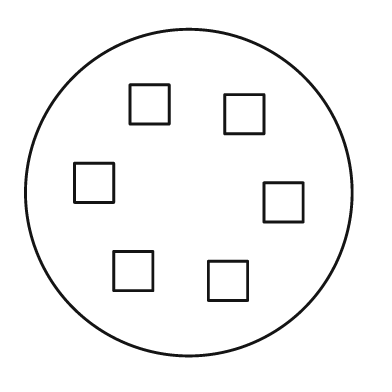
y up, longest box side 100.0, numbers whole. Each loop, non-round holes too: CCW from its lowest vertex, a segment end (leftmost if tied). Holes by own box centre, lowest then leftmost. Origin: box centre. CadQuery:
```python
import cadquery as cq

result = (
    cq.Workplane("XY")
    .moveTo(0.0, 0.0)
    .circle(50.0)
    .moveTo(6.0, -33.0)
    .lineTo(18.0, -33.0)
    .lineTo(18.0, -21.0)
    .lineTo(6.0, -21.0)
    .close()
    .moveTo(-23.0, -30.0)
    .lineTo(-11.0, -30.0)
    .lineTo(-11.0, -18.0)
    .lineTo(-23.0, -18.0)
    .close()
    .moveTo(23.0, -9.0)
    .lineTo(35.0, -9.0)
    .lineTo(35.0, 3.0)
    .lineTo(23.0, 3.0)
    .close()
    .moveTo(-35.0, -3.0)
    .lineTo(-23.0, -3.0)
    .lineTo(-23.0, 9.0)
    .lineTo(-35.0, 9.0)
    .close()
    .moveTo(11.0, 18.0)
    .lineTo(23.0, 18.0)
    .lineTo(23.0, 30.0)
    .lineTo(11.0, 30.0)
    .close()
    .moveTo(-18.0, 21.0)
    .lineTo(-6.0, 21.0)
    .lineTo(-6.0, 33.0)
    .lineTo(-18.0, 33.0)
    .close()
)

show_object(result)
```